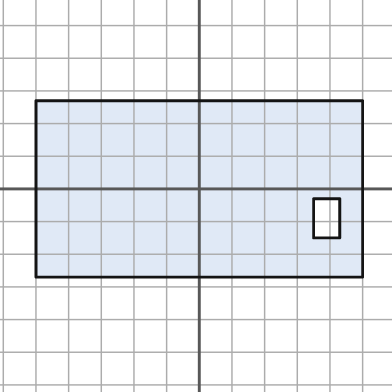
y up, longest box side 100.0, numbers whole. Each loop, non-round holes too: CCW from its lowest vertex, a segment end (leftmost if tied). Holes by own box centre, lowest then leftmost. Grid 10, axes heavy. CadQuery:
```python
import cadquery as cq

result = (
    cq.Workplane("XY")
    .moveTo(-50.0, -27.0)
    .lineTo(50.0, -27.0)
    .lineTo(50.0, 27.0)
    .lineTo(-50.0, 27.0)
    .close()
    .moveTo(35.0, -15.0)
    .lineTo(43.0, -15.0)
    .lineTo(43.0, -3.0)
    .lineTo(35.0, -3.0)
    .close()
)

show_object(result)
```